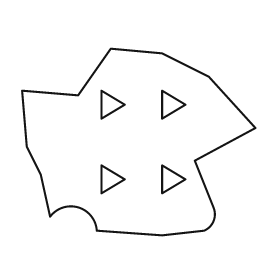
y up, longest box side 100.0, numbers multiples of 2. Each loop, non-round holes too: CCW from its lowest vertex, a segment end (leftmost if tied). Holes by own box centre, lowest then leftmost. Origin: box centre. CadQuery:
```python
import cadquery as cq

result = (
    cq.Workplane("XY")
    .moveTo(10.0, -40.0)
    .lineTo(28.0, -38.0)
    .threePointArc((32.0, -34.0), (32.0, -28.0))
    .lineTo(24.0, -8.0)
    .lineTo(50.0, 6.0)
    .lineTo(30.0, 28.0)
    .lineTo(10.0, 38.0)
    .lineTo(-12.0, 40.0)
    .lineTo(-26.0, 20.0)
    .lineTo(-50.0, 22.0)
    .lineTo(-48.0, -2.0)
    .lineTo(-42.0, -14.0)
    .lineTo(-38.0, -32.0)
    .threePointArc((-26.0, -28.0), (-18.0, -38.0))
    .close()
    .moveTo(-16.0, -22.0)
    .lineTo(-6.0, -16.0)
    .lineTo(-16.0, -10.0)
    .close()
    .moveTo(10.0, -22.0)
    .lineTo(20.0, -16.0)
    .lineTo(10.0, -10.0)
    .close()
    .moveTo(-16.0, 10.0)
    .lineTo(-6.0, 16.0)
    .lineTo(-16.0, 22.0)
    .close()
    .moveTo(10.0, 10.0)
    .lineTo(20.0, 16.0)
    .lineTo(10.0, 22.0)
    .close()
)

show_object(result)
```